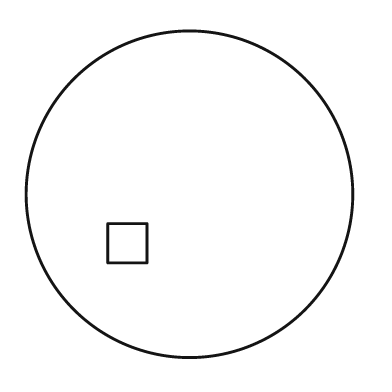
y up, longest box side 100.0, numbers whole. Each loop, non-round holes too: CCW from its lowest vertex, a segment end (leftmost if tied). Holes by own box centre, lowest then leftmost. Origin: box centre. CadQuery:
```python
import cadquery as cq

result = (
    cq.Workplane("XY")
    .moveTo(0.0, 0.0)
    .circle(50.0)
    .moveTo(-25.0, -21.0)
    .lineTo(-13.0, -21.0)
    .lineTo(-13.0, -9.0)
    .lineTo(-25.0, -9.0)
    .close()
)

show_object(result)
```